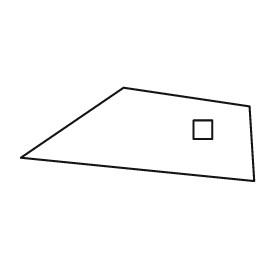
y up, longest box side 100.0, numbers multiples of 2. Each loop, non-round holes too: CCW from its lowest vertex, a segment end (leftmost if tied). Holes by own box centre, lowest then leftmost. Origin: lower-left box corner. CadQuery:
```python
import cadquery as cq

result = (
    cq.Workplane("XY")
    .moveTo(100.0, 0.0)
    .lineTo(98.0, 32.0)
    .lineTo(44.0, 40.0)
    .lineTo(0.0, 10.0)
    .close()
    .moveTo(74.0, 18.0)
    .lineTo(82.0, 18.0)
    .lineTo(82.0, 26.0)
    .lineTo(74.0, 26.0)
    .close()
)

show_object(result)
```